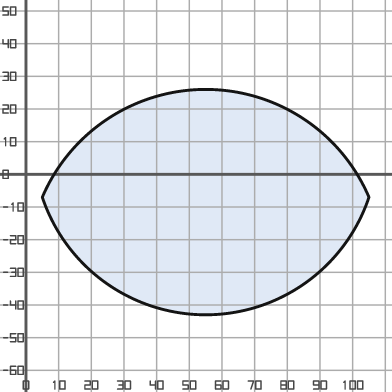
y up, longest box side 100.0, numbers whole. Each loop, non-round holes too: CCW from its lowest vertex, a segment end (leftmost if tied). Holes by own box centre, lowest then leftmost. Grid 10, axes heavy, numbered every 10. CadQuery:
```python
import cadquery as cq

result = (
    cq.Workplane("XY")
    .moveTo(5.0, -7.0)
    .threePointArc((55.0, -43.0), (105.0, -7.0))
    .threePointArc((55.0, 26.0), (5.0, -7.0))
    .close()
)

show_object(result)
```